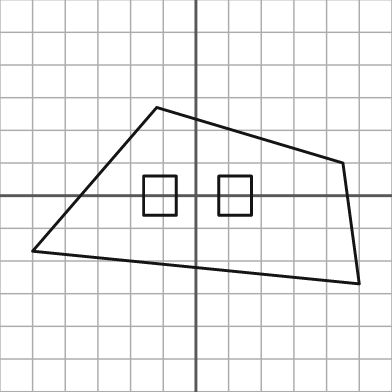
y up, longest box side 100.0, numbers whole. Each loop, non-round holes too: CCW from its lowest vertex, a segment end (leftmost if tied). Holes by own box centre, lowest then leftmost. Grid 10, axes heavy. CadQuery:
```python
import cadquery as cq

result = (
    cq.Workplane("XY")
    .moveTo(50.0, -27.0)
    .lineTo(45.0, 10.0)
    .lineTo(-12.0, 27.0)
    .lineTo(-50.0, -17.0)
    .close()
    .moveTo(-16.0, -6.0)
    .lineTo(-6.0, -6.0)
    .lineTo(-6.0, 6.0)
    .lineTo(-16.0, 6.0)
    .close()
    .moveTo(7.0, -6.0)
    .lineTo(17.0, -6.0)
    .lineTo(17.0, 6.0)
    .lineTo(7.0, 6.0)
    .close()
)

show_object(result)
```